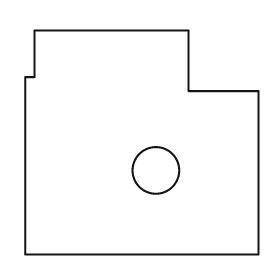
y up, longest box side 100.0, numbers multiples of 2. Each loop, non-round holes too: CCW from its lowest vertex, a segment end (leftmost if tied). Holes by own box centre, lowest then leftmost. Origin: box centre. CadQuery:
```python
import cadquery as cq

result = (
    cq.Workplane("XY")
    .moveTo(-50.0, -48.0)
    .lineTo(50.0, -48.0)
    .lineTo(50.0, 22.0)
    .lineTo(20.0, 22.0)
    .lineTo(20.0, 48.0)
    .lineTo(-46.0, 48.0)
    .lineTo(-46.0, 28.0)
    .lineTo(-50.0, 28.0)
    .close()
    .moveTo(6.0, -12.0)
    .circle(10.0)
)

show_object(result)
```